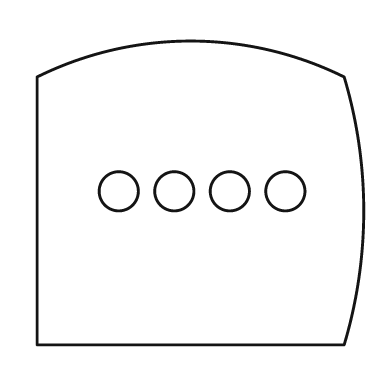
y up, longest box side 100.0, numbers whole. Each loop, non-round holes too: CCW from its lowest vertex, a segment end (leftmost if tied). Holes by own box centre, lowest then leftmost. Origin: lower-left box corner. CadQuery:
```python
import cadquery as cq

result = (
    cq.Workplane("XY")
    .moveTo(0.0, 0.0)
    .lineTo(94.0, 0.0)
    .threePointArc((100.0, 41.0), (94.0, 82.0))
    .threePointArc((47.0, 93.0), (0.0, 82.0))
    .close()
    .moveTo(25.0, 47.0)
    .circle(6.0)
    .moveTo(42.0, 47.0)
    .circle(6.0)
    .moveTo(59.0, 47.0)
    .circle(6.0)
    .moveTo(76.0, 47.0)
    .circle(6.0)
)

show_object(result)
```